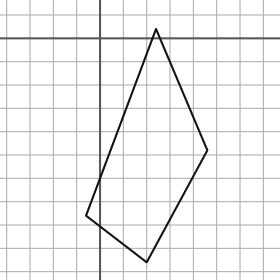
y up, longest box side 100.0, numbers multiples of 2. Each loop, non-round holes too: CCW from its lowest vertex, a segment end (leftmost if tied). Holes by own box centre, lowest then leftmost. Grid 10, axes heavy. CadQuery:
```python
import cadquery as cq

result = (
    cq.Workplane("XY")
    .moveTo(20.0, -96.0)
    .lineTo(46.0, -48.0)
    .lineTo(24.0, 4.0)
    .lineTo(-6.0, -76.0)
    .close()
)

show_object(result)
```